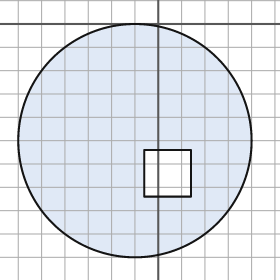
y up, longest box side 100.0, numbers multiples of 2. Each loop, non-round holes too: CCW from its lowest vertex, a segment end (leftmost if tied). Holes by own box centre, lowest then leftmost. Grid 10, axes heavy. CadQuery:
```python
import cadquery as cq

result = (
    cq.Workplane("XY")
    .moveTo(-10.0, -50.0)
    .circle(50.0)
    .moveTo(-6.0, -74.0)
    .lineTo(14.0, -74.0)
    .lineTo(14.0, -54.0)
    .lineTo(-6.0, -54.0)
    .close()
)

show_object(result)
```